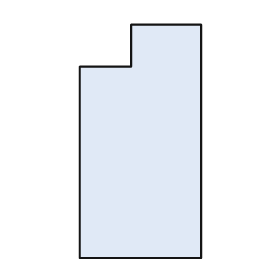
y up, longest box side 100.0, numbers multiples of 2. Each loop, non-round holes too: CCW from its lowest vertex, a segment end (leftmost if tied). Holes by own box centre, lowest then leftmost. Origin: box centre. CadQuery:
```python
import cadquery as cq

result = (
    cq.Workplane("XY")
    .moveTo(-26.0, -50.0)
    .lineTo(26.0, -50.0)
    .lineTo(26.0, 50.0)
    .lineTo(-4.0, 50.0)
    .lineTo(-4.0, 32.0)
    .lineTo(-26.0, 32.0)
    .close()
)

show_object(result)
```